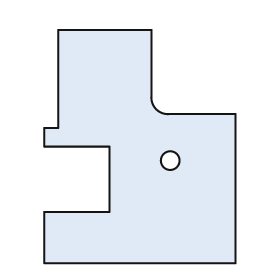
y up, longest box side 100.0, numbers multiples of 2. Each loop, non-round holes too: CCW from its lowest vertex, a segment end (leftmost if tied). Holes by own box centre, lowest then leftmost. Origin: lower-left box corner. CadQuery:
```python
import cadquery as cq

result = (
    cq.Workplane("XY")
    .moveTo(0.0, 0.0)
    .lineTo(82.0, 0.0)
    .lineTo(82.0, 64.0)
    .lineTo(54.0, 64.0)
    .threePointArc((48.0, 66.0), (46.0, 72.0))
    .lineTo(46.0, 100.0)
    .lineTo(6.0, 100.0)
    .lineTo(6.0, 58.0)
    .lineTo(0.0, 58.0)
    .lineTo(0.0, 50.0)
    .lineTo(28.0, 50.0)
    .lineTo(28.0, 22.0)
    .lineTo(0.0, 22.0)
    .close()
    .moveTo(54.0, 44.0)
    .circle(4.0)
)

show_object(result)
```